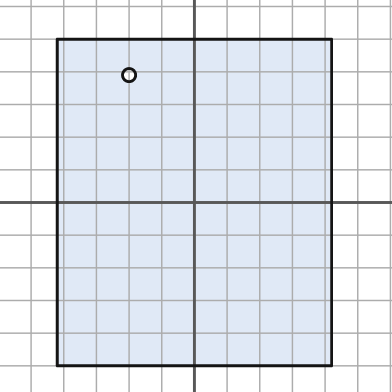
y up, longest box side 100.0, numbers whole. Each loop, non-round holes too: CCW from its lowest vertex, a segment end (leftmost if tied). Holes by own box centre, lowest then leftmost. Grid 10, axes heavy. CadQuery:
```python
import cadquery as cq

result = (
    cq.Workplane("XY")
    .moveTo(-42.0, -50.0)
    .lineTo(42.0, -50.0)
    .lineTo(42.0, 50.0)
    .lineTo(-42.0, 50.0)
    .close()
    .moveTo(-20.0, 39.0)
    .circle(2.0)
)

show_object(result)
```